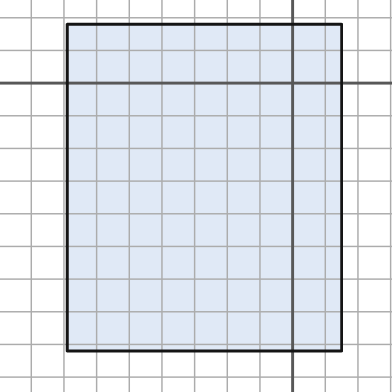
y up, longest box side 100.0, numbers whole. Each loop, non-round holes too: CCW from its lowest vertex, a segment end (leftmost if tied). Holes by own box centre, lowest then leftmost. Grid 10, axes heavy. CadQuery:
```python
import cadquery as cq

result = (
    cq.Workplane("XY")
    .moveTo(-69.0, -82.0)
    .lineTo(15.0, -82.0)
    .lineTo(15.0, 18.0)
    .lineTo(-69.0, 18.0)
    .close()
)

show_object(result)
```